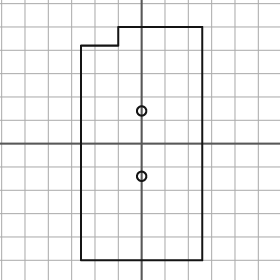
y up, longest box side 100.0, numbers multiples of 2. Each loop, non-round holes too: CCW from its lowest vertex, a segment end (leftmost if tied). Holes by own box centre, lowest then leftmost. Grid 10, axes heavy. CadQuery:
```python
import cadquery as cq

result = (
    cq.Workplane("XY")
    .moveTo(-26.0, -50.0)
    .lineTo(26.0, -50.0)
    .lineTo(26.0, 50.0)
    .lineTo(-10.0, 50.0)
    .lineTo(-10.0, 42.0)
    .lineTo(-26.0, 42.0)
    .close()
    .moveTo(0.0, -14.0)
    .circle(2.0)
    .moveTo(0.0, 14.0)
    .circle(2.0)
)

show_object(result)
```